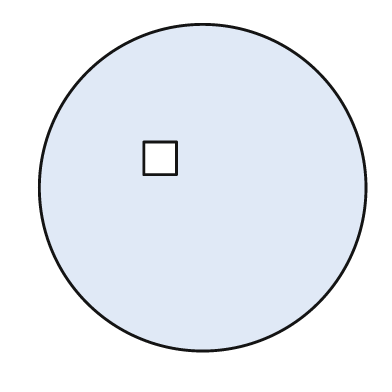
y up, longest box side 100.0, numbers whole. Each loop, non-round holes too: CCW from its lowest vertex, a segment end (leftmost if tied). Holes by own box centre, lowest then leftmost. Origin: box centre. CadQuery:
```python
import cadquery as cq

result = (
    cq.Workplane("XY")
    .moveTo(0.0, 0.0)
    .circle(50.0)
    .moveTo(-18.0, 4.0)
    .lineTo(-8.0, 4.0)
    .lineTo(-8.0, 14.0)
    .lineTo(-18.0, 14.0)
    .close()
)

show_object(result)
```